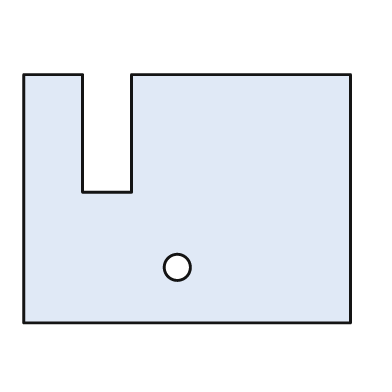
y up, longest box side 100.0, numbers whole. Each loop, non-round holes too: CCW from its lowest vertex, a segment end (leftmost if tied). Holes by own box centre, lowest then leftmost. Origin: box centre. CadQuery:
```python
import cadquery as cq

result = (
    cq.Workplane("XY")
    .moveTo(-50.0, -38.0)
    .lineTo(50.0, -38.0)
    .lineTo(50.0, 38.0)
    .lineTo(-17.0, 38.0)
    .lineTo(-17.0, 2.0)
    .lineTo(-32.0, 2.0)
    .lineTo(-32.0, 38.0)
    .lineTo(-50.0, 38.0)
    .close()
    .moveTo(-3.0, -21.0)
    .circle(4.0)
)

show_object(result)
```